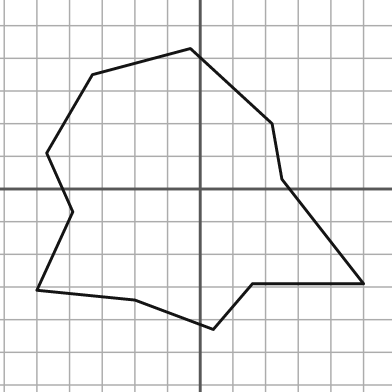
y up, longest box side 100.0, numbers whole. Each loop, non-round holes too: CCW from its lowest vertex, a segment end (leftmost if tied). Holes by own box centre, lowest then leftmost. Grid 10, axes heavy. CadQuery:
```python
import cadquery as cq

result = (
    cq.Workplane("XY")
    .moveTo(4.0, -43.0)
    .lineTo(16.0, -29.0)
    .lineTo(50.0, -29.0)
    .lineTo(25.0, 3.0)
    .lineTo(22.0, 20.0)
    .lineTo(-3.0, 43.0)
    .lineTo(-33.0, 35.0)
    .lineTo(-47.0, 11.0)
    .lineTo(-39.0, -7.0)
    .lineTo(-50.0, -31.0)
    .lineTo(-20.0, -34.0)
    .close()
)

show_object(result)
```